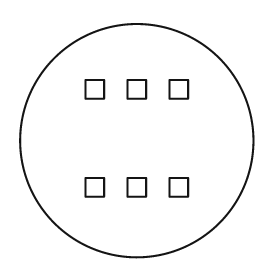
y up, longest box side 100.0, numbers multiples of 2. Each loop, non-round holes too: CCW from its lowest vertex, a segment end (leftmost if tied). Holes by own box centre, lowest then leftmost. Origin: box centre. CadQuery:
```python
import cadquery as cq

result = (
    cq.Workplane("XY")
    .moveTo(0.0, 0.0)
    .circle(50.0)
    .moveTo(-22.0, -24.0)
    .lineTo(-14.0, -24.0)
    .lineTo(-14.0, -16.0)
    .lineTo(-22.0, -16.0)
    .close()
    .moveTo(-4.0, -24.0)
    .lineTo(4.0, -24.0)
    .lineTo(4.0, -16.0)
    .lineTo(-4.0, -16.0)
    .close()
    .moveTo(14.0, -24.0)
    .lineTo(22.0, -24.0)
    .lineTo(22.0, -16.0)
    .lineTo(14.0, -16.0)
    .close()
    .moveTo(-22.0, 18.0)
    .lineTo(-14.0, 18.0)
    .lineTo(-14.0, 26.0)
    .lineTo(-22.0, 26.0)
    .close()
    .moveTo(-4.0, 18.0)
    .lineTo(4.0, 18.0)
    .lineTo(4.0, 26.0)
    .lineTo(-4.0, 26.0)
    .close()
    .moveTo(14.0, 18.0)
    .lineTo(22.0, 18.0)
    .lineTo(22.0, 26.0)
    .lineTo(14.0, 26.0)
    .close()
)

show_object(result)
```